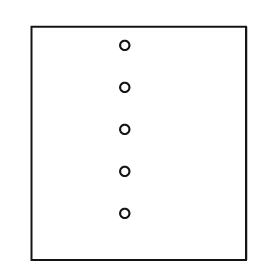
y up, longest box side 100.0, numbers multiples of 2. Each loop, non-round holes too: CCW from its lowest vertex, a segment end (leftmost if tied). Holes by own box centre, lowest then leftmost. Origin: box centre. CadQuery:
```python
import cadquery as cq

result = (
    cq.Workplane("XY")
    .moveTo(-46.0, -50.0)
    .lineTo(46.0, -50.0)
    .lineTo(46.0, 50.0)
    .lineTo(-46.0, 50.0)
    .close()
    .moveTo(-6.0, -30.0)
    .circle(2.0)
    .moveTo(-6.0, -12.0)
    .circle(2.0)
    .moveTo(-6.0, 6.0)
    .circle(2.0)
    .moveTo(-6.0, 24.0)
    .circle(2.0)
    .moveTo(-6.0, 42.0)
    .circle(2.0)
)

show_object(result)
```